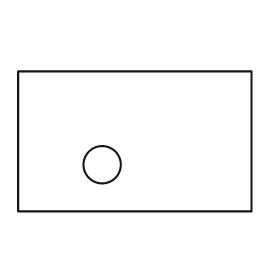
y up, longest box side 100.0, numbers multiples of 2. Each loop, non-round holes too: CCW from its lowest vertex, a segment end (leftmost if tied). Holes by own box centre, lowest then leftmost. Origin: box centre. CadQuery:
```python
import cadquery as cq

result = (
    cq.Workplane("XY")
    .moveTo(-50.0, -30.0)
    .lineTo(50.0, -30.0)
    .lineTo(50.0, 30.0)
    .lineTo(-50.0, 30.0)
    .close()
    .moveTo(-14.0, -10.0)
    .circle(8.0)
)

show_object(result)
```